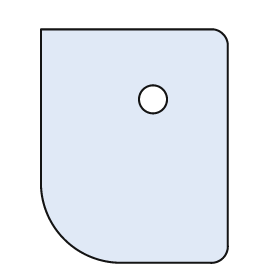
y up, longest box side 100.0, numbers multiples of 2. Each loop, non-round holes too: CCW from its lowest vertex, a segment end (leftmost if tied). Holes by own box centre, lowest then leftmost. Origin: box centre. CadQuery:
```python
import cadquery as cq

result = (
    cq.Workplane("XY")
    .moveTo(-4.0, -50.0)
    .lineTo(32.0, -50.0)
    .threePointArc((38.0, -48.0), (40.0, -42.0))
    .lineTo(40.0, 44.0)
    .threePointArc((38.0, 48.0), (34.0, 50.0))
    .lineTo(-40.0, 50.0)
    .lineTo(-40.0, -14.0)
    .threePointArc((-30.0, -40.0), (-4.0, -50.0))
    .close()
    .moveTo(8.0, 20.0)
    .circle(6.0)
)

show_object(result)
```